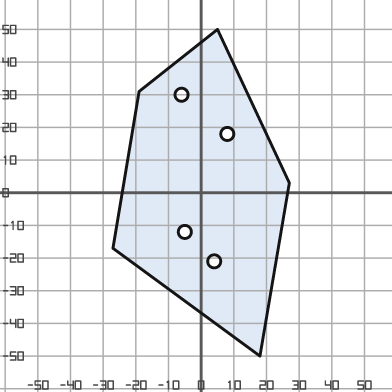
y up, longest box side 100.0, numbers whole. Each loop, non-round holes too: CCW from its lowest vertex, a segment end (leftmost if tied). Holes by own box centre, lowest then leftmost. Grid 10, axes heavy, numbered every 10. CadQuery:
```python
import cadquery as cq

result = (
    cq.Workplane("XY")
    .moveTo(18.0, -50.0)
    .lineTo(27.0, 3.0)
    .lineTo(5.0, 50.0)
    .lineTo(-19.0, 31.0)
    .lineTo(-27.0, -17.0)
    .close()
    .moveTo(4.0, -21.0)
    .circle(2.0)
    .moveTo(-5.0, -12.0)
    .circle(2.0)
    .moveTo(8.0, 18.0)
    .circle(2.0)
    .moveTo(-6.0, 30.0)
    .circle(2.0)
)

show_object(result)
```